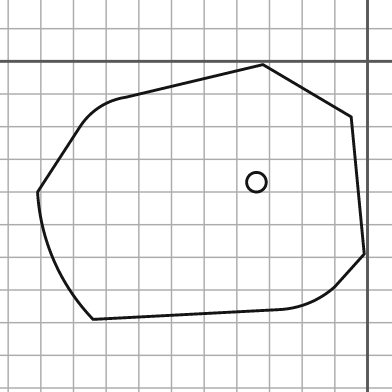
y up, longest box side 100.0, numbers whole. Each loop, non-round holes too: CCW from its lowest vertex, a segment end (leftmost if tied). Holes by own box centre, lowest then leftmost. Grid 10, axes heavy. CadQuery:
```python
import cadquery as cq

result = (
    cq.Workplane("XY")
    .moveTo(-84.0, -79.0)
    .lineTo(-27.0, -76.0)
    .threePointArc((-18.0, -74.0), (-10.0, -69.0))
    .lineTo(-1.0, -59.0)
    .lineTo(-5.0, -17.0)
    .lineTo(-32.0, -1.0)
    .lineTo(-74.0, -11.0)
    .threePointArc((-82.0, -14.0), (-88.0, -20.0))
    .lineTo(-101.0, -40.0)
    .threePointArc((-96.0, -61.0), (-84.0, -79.0))
    .close()
    .moveTo(-34.0, -37.0)
    .circle(3.0)
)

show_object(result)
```